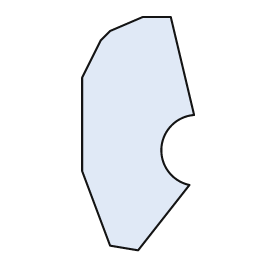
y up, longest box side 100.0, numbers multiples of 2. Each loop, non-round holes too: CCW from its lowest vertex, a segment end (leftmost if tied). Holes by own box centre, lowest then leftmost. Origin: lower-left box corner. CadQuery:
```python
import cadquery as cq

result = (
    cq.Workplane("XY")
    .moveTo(24.0, 0.0)
    .lineTo(46.0, 28.0)
    .threePointArc((34.0, 44.0), (48.0, 58.0))
    .lineTo(38.0, 100.0)
    .lineTo(26.0, 100.0)
    .lineTo(12.0, 94.0)
    .lineTo(8.0, 90.0)
    .lineTo(0.0, 74.0)
    .lineTo(0.0, 34.0)
    .lineTo(12.0, 2.0)
    .close()
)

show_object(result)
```